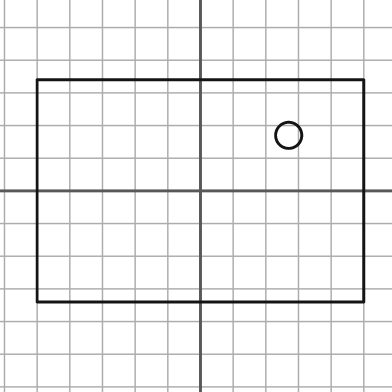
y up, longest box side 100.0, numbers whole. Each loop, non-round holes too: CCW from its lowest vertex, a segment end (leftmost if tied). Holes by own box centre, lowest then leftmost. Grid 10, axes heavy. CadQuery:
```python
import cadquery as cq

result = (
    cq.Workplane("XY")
    .moveTo(-50.0, -34.0)
    .lineTo(50.0, -34.0)
    .lineTo(50.0, 34.0)
    .lineTo(-50.0, 34.0)
    .close()
    .moveTo(27.0, 17.0)
    .circle(4.0)
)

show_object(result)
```